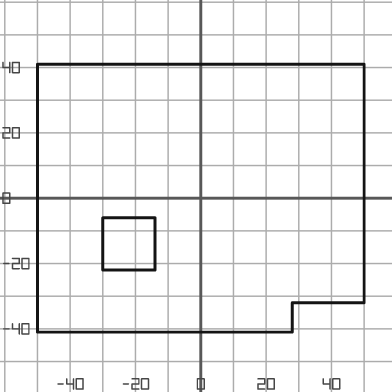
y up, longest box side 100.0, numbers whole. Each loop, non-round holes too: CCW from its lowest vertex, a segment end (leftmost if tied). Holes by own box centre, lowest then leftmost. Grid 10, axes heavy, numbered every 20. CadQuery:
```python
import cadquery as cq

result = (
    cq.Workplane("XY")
    .moveTo(-50.0, -41.0)
    .lineTo(28.0, -41.0)
    .lineTo(28.0, -32.0)
    .lineTo(50.0, -32.0)
    .lineTo(50.0, 41.0)
    .lineTo(-50.0, 41.0)
    .close()
    .moveTo(-30.0, -22.0)
    .lineTo(-14.0, -22.0)
    .lineTo(-14.0, -6.0)
    .lineTo(-30.0, -6.0)
    .close()
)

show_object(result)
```